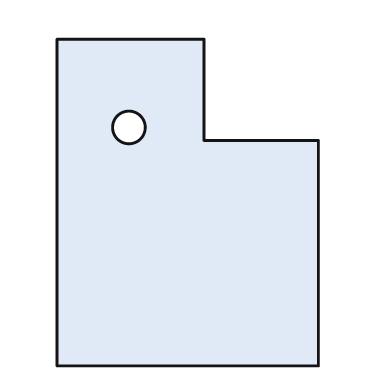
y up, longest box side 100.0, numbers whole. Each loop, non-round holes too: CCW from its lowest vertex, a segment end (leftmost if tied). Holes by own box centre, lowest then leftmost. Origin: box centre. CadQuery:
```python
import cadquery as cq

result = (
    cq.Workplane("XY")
    .moveTo(-40.0, -50.0)
    .lineTo(40.0, -50.0)
    .lineTo(40.0, 19.0)
    .lineTo(5.0, 19.0)
    .lineTo(5.0, 50.0)
    .lineTo(-40.0, 50.0)
    .close()
    .moveTo(-18.0, 23.0)
    .circle(5.0)
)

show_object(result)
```